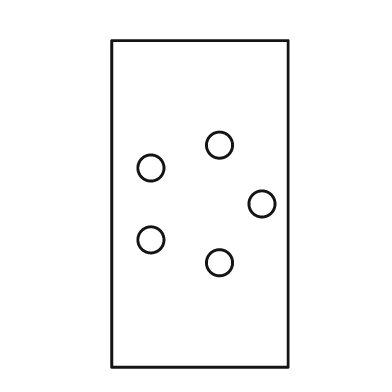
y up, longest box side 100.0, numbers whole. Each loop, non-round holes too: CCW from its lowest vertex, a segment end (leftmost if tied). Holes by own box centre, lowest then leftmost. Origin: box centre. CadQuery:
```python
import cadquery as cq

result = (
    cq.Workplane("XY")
    .moveTo(-27.0, -50.0)
    .lineTo(27.0, -50.0)
    .lineTo(27.0, 50.0)
    .lineTo(-27.0, 50.0)
    .close()
    .moveTo(6.0, -18.0)
    .circle(4.0)
    .moveTo(-15.0, -11.0)
    .circle(4.0)
    .moveTo(19.0, 0.0)
    .circle(4.0)
    .moveTo(-15.0, 11.0)
    .circle(4.0)
    .moveTo(6.0, 18.0)
    .circle(4.0)
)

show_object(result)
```